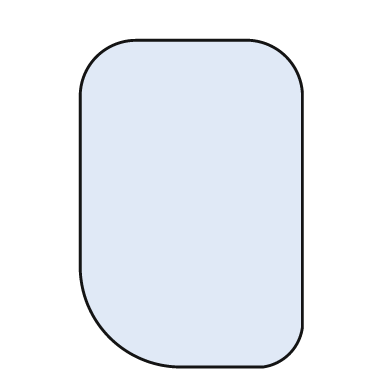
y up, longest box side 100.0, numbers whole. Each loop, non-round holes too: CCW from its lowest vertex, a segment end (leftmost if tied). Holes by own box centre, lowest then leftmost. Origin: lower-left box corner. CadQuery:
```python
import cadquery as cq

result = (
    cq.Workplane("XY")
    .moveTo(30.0, 0.0)
    .lineTo(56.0, 0.0)
    .threePointArc((64.0, 4.0), (68.0, 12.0))
    .lineTo(68.0, 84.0)
    .threePointArc((63.0, 95.0), (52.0, 100.0))
    .lineTo(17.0, 100.0)
    .threePointArc((5.0, 95.0), (0.0, 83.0))
    .lineTo(0.0, 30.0)
    .threePointArc((9.0, 9.0), (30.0, 0.0))
    .close()
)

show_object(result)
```